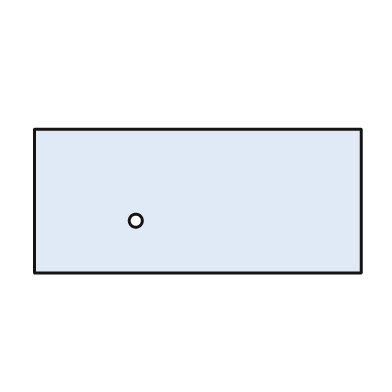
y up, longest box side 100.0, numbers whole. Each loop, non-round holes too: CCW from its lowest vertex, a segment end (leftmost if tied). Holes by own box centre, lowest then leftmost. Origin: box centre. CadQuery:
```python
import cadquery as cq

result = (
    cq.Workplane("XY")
    .moveTo(-50.0, -22.0)
    .lineTo(50.0, -22.0)
    .lineTo(50.0, 22.0)
    .lineTo(-50.0, 22.0)
    .close()
    .moveTo(-19.0, -6.0)
    .circle(2.0)
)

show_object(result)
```